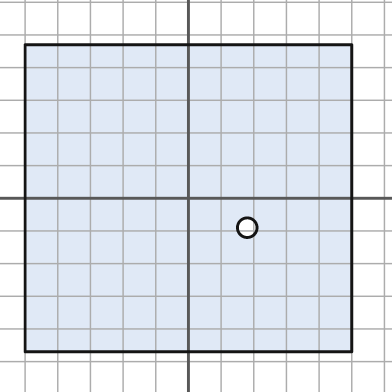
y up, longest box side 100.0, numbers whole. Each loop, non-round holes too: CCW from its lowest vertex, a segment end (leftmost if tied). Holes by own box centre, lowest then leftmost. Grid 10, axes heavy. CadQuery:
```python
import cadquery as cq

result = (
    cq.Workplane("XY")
    .moveTo(-50.0, -47.0)
    .lineTo(50.0, -47.0)
    .lineTo(50.0, 47.0)
    .lineTo(-50.0, 47.0)
    .close()
    .moveTo(18.0, -9.0)
    .circle(3.0)
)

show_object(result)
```